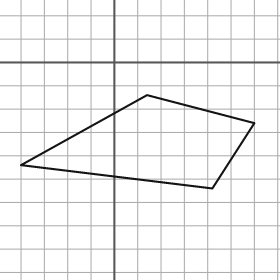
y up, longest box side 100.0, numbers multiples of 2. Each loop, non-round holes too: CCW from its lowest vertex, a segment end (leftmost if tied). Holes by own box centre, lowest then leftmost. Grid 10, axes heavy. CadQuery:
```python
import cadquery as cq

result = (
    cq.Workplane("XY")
    .moveTo(42.0, -54.0)
    .lineTo(60.0, -26.0)
    .lineTo(14.0, -14.0)
    .lineTo(-40.0, -44.0)
    .close()
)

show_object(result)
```